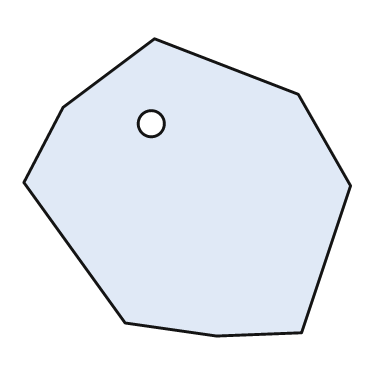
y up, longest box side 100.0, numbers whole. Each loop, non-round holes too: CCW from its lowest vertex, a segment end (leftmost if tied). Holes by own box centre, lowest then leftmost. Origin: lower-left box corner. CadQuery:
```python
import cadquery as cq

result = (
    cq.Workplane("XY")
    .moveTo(59.0, 0.0)
    .lineTo(85.0, 1.0)
    .lineTo(100.0, 46.0)
    .lineTo(84.0, 74.0)
    .lineTo(40.0, 91.0)
    .lineTo(12.0, 70.0)
    .lineTo(0.0, 47.0)
    .lineTo(31.0, 4.0)
    .close()
    .moveTo(39.0, 65.0)
    .circle(4.0)
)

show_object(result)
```